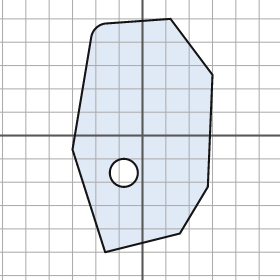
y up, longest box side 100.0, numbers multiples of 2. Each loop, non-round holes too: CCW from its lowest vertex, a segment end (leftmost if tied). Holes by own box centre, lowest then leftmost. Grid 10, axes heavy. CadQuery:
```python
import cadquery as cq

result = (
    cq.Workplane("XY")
    .moveTo(-16.0, -50.0)
    .lineTo(16.0, -42.0)
    .lineTo(28.0, -22.0)
    .lineTo(30.0, 26.0)
    .lineTo(12.0, 50.0)
    .lineTo(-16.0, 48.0)
    .threePointArc((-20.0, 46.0), (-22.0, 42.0))
    .lineTo(-30.0, -6.0)
    .close()
    .moveTo(-8.0, -16.0)
    .circle(6.0)
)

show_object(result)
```